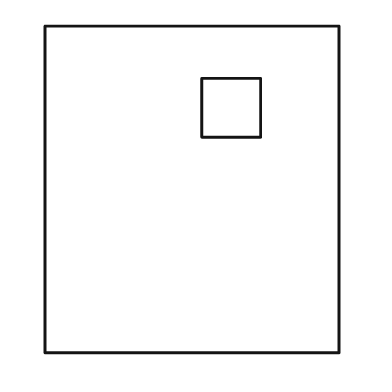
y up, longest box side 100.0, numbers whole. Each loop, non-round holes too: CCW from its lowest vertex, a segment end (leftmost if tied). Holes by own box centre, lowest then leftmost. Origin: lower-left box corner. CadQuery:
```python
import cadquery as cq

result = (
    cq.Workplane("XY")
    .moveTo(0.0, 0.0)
    .lineTo(90.0, 0.0)
    .lineTo(90.0, 100.0)
    .lineTo(0.0, 100.0)
    .close()
    .moveTo(48.0, 66.0)
    .lineTo(66.0, 66.0)
    .lineTo(66.0, 84.0)
    .lineTo(48.0, 84.0)
    .close()
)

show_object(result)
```